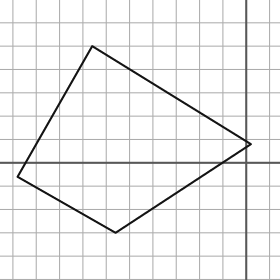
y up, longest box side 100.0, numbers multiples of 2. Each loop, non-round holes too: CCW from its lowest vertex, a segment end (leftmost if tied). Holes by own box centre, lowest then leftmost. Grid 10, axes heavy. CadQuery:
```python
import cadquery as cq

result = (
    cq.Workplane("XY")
    .moveTo(-56.0, -30.0)
    .lineTo(2.0, 8.0)
    .lineTo(-66.0, 50.0)
    .lineTo(-98.0, -6.0)
    .close()
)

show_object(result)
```